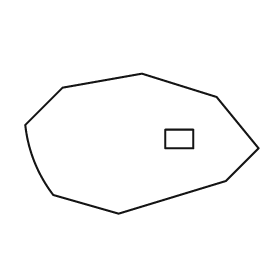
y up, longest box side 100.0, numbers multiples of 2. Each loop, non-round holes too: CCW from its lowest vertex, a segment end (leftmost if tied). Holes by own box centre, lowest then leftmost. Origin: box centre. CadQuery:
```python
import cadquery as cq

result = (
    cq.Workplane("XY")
    .moveTo(-10.0, -30.0)
    .lineTo(36.0, -16.0)
    .lineTo(50.0, -2.0)
    .lineTo(32.0, 20.0)
    .lineTo(0.0, 30.0)
    .lineTo(-34.0, 24.0)
    .lineTo(-50.0, 8.0)
    .threePointArc((-46.0, -8.0), (-38.0, -22.0))
    .close()
    .moveTo(10.0, -2.0)
    .lineTo(22.0, -2.0)
    .lineTo(22.0, 6.0)
    .lineTo(10.0, 6.0)
    .close()
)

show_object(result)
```